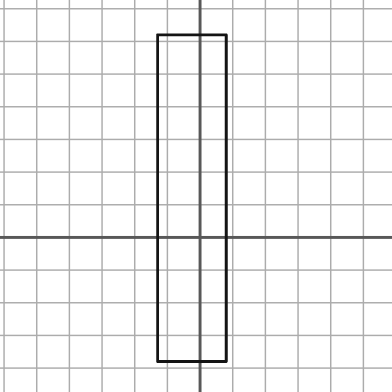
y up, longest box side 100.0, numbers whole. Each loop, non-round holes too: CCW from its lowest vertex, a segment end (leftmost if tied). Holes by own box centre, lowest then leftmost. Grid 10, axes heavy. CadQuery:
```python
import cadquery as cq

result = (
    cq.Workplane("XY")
    .moveTo(-13.0, -38.0)
    .lineTo(8.0, -38.0)
    .lineTo(8.0, 62.0)
    .lineTo(-13.0, 62.0)
    .close()
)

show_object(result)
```